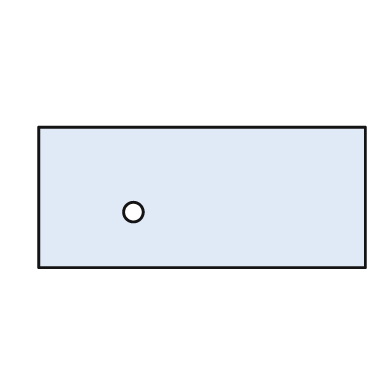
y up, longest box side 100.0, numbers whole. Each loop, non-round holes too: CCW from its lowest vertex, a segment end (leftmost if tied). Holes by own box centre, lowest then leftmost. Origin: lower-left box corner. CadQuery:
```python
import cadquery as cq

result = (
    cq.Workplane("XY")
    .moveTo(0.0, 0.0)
    .lineTo(100.0, 0.0)
    .lineTo(100.0, 43.0)
    .lineTo(0.0, 43.0)
    .close()
    .moveTo(29.0, 17.0)
    .circle(3.0)
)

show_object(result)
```